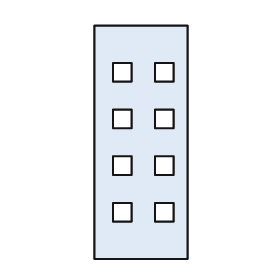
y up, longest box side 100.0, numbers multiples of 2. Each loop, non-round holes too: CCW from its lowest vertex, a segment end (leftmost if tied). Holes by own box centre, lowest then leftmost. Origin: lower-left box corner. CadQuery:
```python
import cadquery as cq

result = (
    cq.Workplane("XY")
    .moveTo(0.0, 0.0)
    .lineTo(40.0, 0.0)
    .lineTo(40.0, 100.0)
    .lineTo(0.0, 100.0)
    .close()
    .moveTo(8.0, 16.0)
    .lineTo(16.0, 16.0)
    .lineTo(16.0, 24.0)
    .lineTo(8.0, 24.0)
    .close()
    .moveTo(26.0, 16.0)
    .lineTo(34.0, 16.0)
    .lineTo(34.0, 24.0)
    .lineTo(26.0, 24.0)
    .close()
    .moveTo(8.0, 36.0)
    .lineTo(16.0, 36.0)
    .lineTo(16.0, 44.0)
    .lineTo(8.0, 44.0)
    .close()
    .moveTo(26.0, 36.0)
    .lineTo(34.0, 36.0)
    .lineTo(34.0, 44.0)
    .lineTo(26.0, 44.0)
    .close()
    .moveTo(8.0, 56.0)
    .lineTo(16.0, 56.0)
    .lineTo(16.0, 64.0)
    .lineTo(8.0, 64.0)
    .close()
    .moveTo(26.0, 56.0)
    .lineTo(34.0, 56.0)
    .lineTo(34.0, 64.0)
    .lineTo(26.0, 64.0)
    .close()
    .moveTo(8.0, 76.0)
    .lineTo(16.0, 76.0)
    .lineTo(16.0, 84.0)
    .lineTo(8.0, 84.0)
    .close()
    .moveTo(26.0, 76.0)
    .lineTo(34.0, 76.0)
    .lineTo(34.0, 84.0)
    .lineTo(26.0, 84.0)
    .close()
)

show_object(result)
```